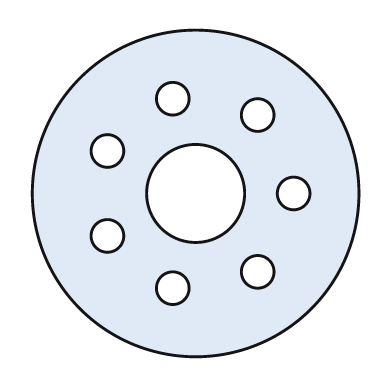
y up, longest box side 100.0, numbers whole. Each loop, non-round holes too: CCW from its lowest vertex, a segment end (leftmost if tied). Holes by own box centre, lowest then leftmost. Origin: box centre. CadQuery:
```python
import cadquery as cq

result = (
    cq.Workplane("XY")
    .moveTo(0.0, 0.0)
    .circle(50.0)
    .moveTo(-7.0, -29.0)
    .circle(5.0)
    .moveTo(19.0, -24.0)
    .circle(5.0)
    .moveTo(-27.0, -13.0)
    .circle(5.0)
    .moveTo(0.0, 0.0)
    .circle(15.0)
    .moveTo(30.0, 0.0)
    .circle(5.0)
    .moveTo(-27.0, 13.0)
    .circle(5.0)
    .moveTo(19.0, 24.0)
    .circle(5.0)
    .moveTo(-7.0, 29.0)
    .circle(5.0)
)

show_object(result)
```